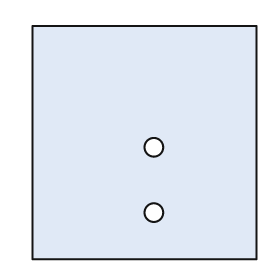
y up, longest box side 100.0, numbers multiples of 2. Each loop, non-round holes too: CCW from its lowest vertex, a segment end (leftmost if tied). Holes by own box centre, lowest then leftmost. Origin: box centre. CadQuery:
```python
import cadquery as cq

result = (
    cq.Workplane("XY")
    .moveTo(-48.0, -50.0)
    .lineTo(48.0, -50.0)
    .lineTo(48.0, 50.0)
    .lineTo(-48.0, 50.0)
    .close()
    .moveTo(4.0, -30.0)
    .circle(4.0)
    .moveTo(4.0, -2.0)
    .circle(4.0)
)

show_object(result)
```